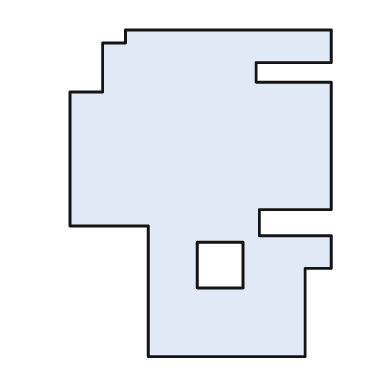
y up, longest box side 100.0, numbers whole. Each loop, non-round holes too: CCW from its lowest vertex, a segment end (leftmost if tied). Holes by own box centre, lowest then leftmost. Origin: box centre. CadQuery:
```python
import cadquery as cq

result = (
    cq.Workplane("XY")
    .moveTo(-16.0, -50.0)
    .lineTo(32.0, -50.0)
    .lineTo(32.0, -23.0)
    .lineTo(40.0, -23.0)
    .lineTo(40.0, -13.0)
    .lineTo(18.0, -13.0)
    .lineTo(18.0, -5.0)
    .lineTo(40.0, -5.0)
    .lineTo(40.0, 34.0)
    .lineTo(17.0, 34.0)
    .lineTo(17.0, 40.0)
    .lineTo(40.0, 40.0)
    .lineTo(40.0, 50.0)
    .lineTo(-23.0, 50.0)
    .lineTo(-23.0, 46.0)
    .lineTo(-30.0, 46.0)
    .lineTo(-30.0, 31.0)
    .lineTo(-40.0, 31.0)
    .lineTo(-40.0, -10.0)
    .lineTo(-16.0, -10.0)
    .close()
    .moveTo(-1.0, -29.0)
    .lineTo(13.0, -29.0)
    .lineTo(13.0, -15.0)
    .lineTo(-1.0, -15.0)
    .close()
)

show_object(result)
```